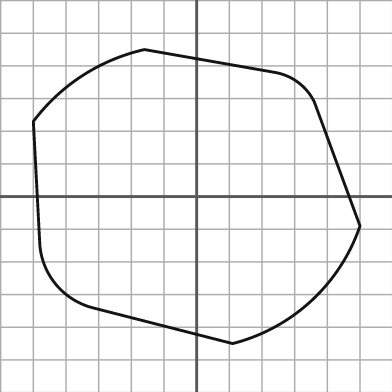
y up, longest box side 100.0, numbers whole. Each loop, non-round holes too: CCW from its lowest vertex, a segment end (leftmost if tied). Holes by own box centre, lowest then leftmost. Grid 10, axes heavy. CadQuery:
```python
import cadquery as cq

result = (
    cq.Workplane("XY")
    .moveTo(11.0, -45.0)
    .threePointArc((35.0, -32.0), (50.0, -9.0))
    .lineTo(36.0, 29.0)
    .threePointArc((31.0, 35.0), (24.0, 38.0))
    .lineTo(-16.0, 45.0)
    .threePointArc((-35.0, 37.0), (-50.0, 23.0))
    .lineTo(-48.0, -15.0)
    .threePointArc((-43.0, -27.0), (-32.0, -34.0))
    .close()
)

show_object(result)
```